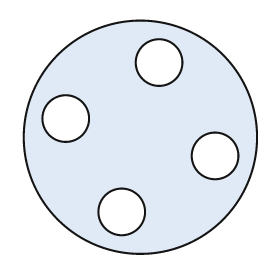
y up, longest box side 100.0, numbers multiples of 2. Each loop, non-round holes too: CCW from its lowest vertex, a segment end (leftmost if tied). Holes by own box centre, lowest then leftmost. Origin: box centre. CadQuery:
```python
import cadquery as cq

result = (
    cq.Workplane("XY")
    .moveTo(0.0, 0.0)
    .circle(50.0)
    .moveTo(-8.0, -32.0)
    .circle(10.0)
    .moveTo(32.0, -8.0)
    .circle(10.0)
    .moveTo(-32.0, 8.0)
    .circle(10.0)
    .moveTo(8.0, 32.0)
    .circle(10.0)
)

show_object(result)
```